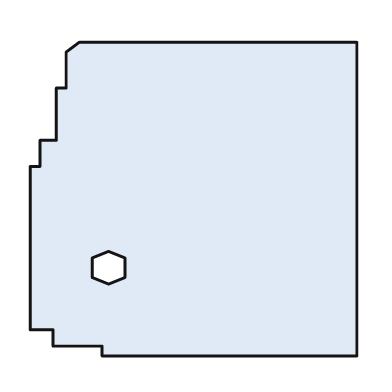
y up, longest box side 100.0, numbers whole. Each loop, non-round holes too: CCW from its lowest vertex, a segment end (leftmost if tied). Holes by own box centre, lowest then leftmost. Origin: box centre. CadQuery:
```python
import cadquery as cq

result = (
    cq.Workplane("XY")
    .moveTo(-28.0, -48.0)
    .lineTo(50.0, -48.0)
    .lineTo(50.0, 48.0)
    .lineTo(-35.0, 48.0)
    .lineTo(-39.0, 45.0)
    .lineTo(-39.0, 34.0)
    .lineTo(-42.0, 34.0)
    .lineTo(-42.0, 18.0)
    .lineTo(-47.0, 18.0)
    .lineTo(-47.0, 10.0)
    .lineTo(-50.0, 10.0)
    .lineTo(-50.0, -40.0)
    .lineTo(-43.0, -40.0)
    .lineTo(-43.0, -45.0)
    .lineTo(-28.0, -45.0)
    .close()
    .moveTo(-26.0, -26.0)
    .lineTo(-21.0, -24.0)
    .lineTo(-21.0, -18.0)
    .lineTo(-26.0, -16.0)
    .lineTo(-31.0, -18.0)
    .lineTo(-31.0, -24.0)
    .close()
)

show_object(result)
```